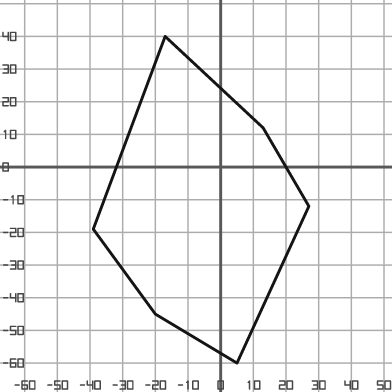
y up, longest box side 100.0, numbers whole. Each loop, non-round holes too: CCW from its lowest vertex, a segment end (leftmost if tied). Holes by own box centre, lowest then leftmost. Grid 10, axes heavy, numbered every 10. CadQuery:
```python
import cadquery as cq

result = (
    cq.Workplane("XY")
    .moveTo(5.0, -60.0)
    .lineTo(27.0, -12.0)
    .lineTo(13.0, 12.0)
    .lineTo(-17.0, 40.0)
    .lineTo(-39.0, -19.0)
    .lineTo(-20.0, -45.0)
    .close()
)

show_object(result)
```